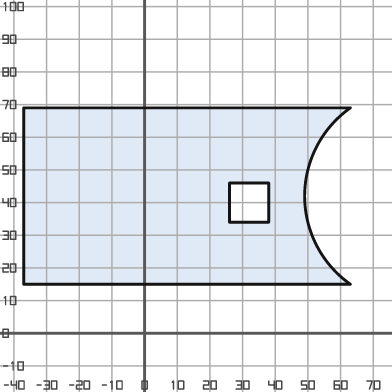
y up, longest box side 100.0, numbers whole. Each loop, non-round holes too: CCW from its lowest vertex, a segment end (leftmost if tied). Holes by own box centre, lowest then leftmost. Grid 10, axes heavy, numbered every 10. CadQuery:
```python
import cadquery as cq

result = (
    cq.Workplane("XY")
    .moveTo(-37.0, 15.0)
    .lineTo(63.0, 15.0)
    .threePointArc((49.0, 42.0), (63.0, 69.0))
    .lineTo(-37.0, 69.0)
    .close()
    .moveTo(26.0, 34.0)
    .lineTo(38.0, 34.0)
    .lineTo(38.0, 46.0)
    .lineTo(26.0, 46.0)
    .close()
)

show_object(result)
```